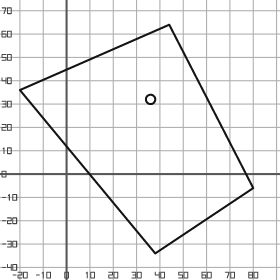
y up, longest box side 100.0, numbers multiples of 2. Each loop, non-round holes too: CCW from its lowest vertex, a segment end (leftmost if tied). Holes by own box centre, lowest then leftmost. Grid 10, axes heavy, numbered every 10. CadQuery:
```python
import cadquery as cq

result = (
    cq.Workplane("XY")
    .moveTo(38.0, -34.0)
    .lineTo(80.0, -6.0)
    .lineTo(44.0, 64.0)
    .lineTo(-20.0, 36.0)
    .close()
    .moveTo(36.0, 32.0)
    .circle(2.0)
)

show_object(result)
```